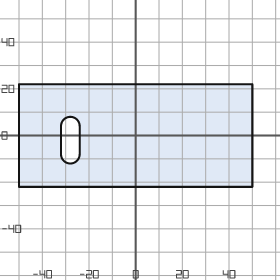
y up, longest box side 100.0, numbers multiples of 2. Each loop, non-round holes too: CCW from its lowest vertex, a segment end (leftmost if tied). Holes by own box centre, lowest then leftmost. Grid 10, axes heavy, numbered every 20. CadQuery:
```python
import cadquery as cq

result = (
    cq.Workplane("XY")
    .moveTo(-50.0, -22.0)
    .lineTo(50.0, -22.0)
    .lineTo(50.0, 22.0)
    .lineTo(-50.0, 22.0)
    .close()
    .moveTo(-32.0, -8.0)
    .threePointArc((-28.0, -12.0), (-24.0, -8.0))
    .lineTo(-24.0, 4.0)
    .threePointArc((-28.0, 8.0), (-32.0, 4.0))
    .close()
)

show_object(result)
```